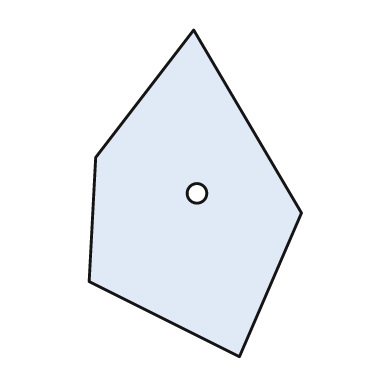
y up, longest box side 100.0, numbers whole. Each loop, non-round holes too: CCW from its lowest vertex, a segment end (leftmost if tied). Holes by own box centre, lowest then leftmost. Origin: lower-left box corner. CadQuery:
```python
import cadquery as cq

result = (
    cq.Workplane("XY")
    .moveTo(46.0, 0.0)
    .lineTo(65.0, 44.0)
    .lineTo(32.0, 100.0)
    .lineTo(2.0, 61.0)
    .lineTo(0.0, 23.0)
    .close()
    .moveTo(33.0, 50.0)
    .circle(3.0)
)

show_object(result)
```